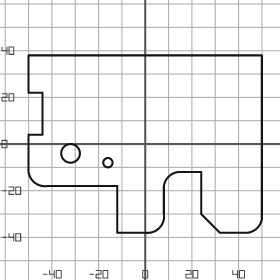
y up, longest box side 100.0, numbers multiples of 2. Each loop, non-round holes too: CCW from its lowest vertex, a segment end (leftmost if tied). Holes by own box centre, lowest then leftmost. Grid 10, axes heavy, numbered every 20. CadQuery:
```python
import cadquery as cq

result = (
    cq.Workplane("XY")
    .moveTo(-12.0, -38.0)
    .lineTo(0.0, -38.0)
    .threePointArc((6.0, -36.0), (8.0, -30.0))
    .lineTo(8.0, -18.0)
    .threePointArc((10.0, -14.0), (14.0, -12.0))
    .lineTo(24.0, -12.0)
    .lineTo(24.0, -30.0)
    .lineTo(32.0, -38.0)
    .lineTo(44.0, -38.0)
    .threePointArc((48.0, -36.0), (50.0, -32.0))
    .lineTo(50.0, 38.0)
    .lineTo(-50.0, 38.0)
    .lineTo(-50.0, 22.0)
    .lineTo(-44.0, 22.0)
    .lineTo(-44.0, 4.0)
    .lineTo(-50.0, 4.0)
    .lineTo(-50.0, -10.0)
    .threePointArc((-48.0, -16.0), (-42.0, -18.0))
    .lineTo(-12.0, -18.0)
    .close()
    .moveTo(-16.0, -8.0)
    .circle(2.0)
    .moveTo(-32.0, -4.0)
    .circle(4.0)
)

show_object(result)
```